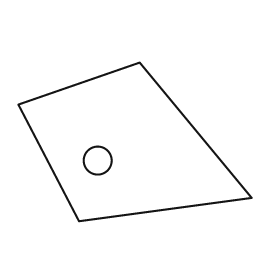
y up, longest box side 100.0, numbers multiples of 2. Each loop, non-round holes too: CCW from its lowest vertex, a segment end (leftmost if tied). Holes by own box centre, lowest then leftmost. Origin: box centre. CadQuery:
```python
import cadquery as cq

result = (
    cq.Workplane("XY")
    .moveTo(-24.0, -34.0)
    .lineTo(50.0, -24.0)
    .lineTo(2.0, 34.0)
    .lineTo(-50.0, 16.0)
    .close()
    .moveTo(-16.0, -8.0)
    .circle(6.0)
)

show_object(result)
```